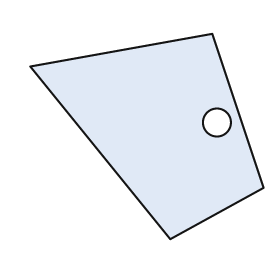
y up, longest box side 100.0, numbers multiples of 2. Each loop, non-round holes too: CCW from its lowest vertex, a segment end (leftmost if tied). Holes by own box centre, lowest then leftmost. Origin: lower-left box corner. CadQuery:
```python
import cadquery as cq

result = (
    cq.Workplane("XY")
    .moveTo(60.0, 0.0)
    .lineTo(100.0, 22.0)
    .lineTo(78.0, 88.0)
    .lineTo(0.0, 74.0)
    .close()
    .moveTo(80.0, 50.0)
    .circle(6.0)
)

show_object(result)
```